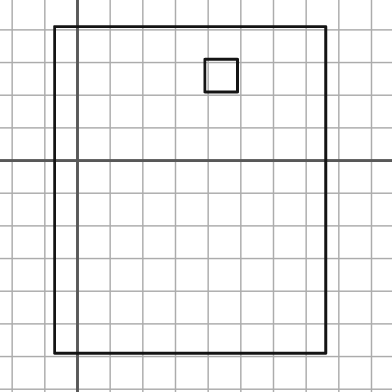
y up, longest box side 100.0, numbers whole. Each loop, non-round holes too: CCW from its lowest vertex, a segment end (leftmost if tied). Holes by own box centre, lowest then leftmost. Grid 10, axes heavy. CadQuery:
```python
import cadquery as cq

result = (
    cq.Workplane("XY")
    .moveTo(-7.0, -59.0)
    .lineTo(76.0, -59.0)
    .lineTo(76.0, 41.0)
    .lineTo(-7.0, 41.0)
    .close()
    .moveTo(39.0, 21.0)
    .lineTo(49.0, 21.0)
    .lineTo(49.0, 31.0)
    .lineTo(39.0, 31.0)
    .close()
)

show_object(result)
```